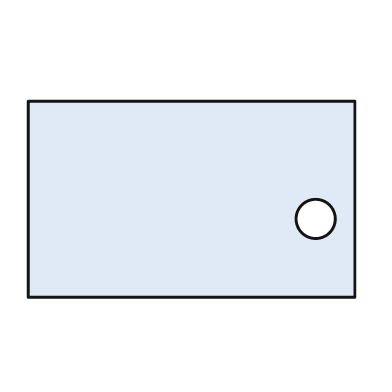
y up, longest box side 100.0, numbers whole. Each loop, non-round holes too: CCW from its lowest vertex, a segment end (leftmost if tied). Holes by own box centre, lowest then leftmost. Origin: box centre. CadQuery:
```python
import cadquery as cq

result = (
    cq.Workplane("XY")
    .moveTo(-50.0, -30.0)
    .lineTo(50.0, -30.0)
    .lineTo(50.0, 30.0)
    .lineTo(-50.0, 30.0)
    .close()
    .moveTo(38.0, -6.0)
    .circle(6.0)
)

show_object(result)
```